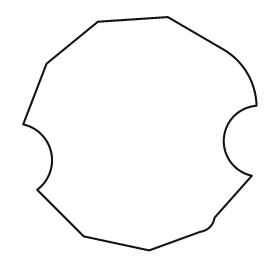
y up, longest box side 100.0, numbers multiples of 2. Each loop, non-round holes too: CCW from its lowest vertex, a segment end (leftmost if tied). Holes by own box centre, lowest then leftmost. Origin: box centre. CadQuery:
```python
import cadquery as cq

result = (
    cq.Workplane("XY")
    .moveTo(4.0, -50.0)
    .lineTo(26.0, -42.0)
    .threePointArc((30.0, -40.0), (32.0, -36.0))
    .lineTo(48.0, -18.0)
    .threePointArc((36.0, -2.0), (50.0, 12.0))
    .threePointArc((46.0, 26.0), (36.0, 36.0))
    .lineTo(12.0, 50.0)
    .lineTo(-18.0, 48.0)
    .lineTo(-40.0, 30.0)
    .lineTo(-50.0, 4.0)
    .threePointArc((-38.0, -8.0), (-44.0, -24.0))
    .lineTo(-24.0, -44.0)
    .close()
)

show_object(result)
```